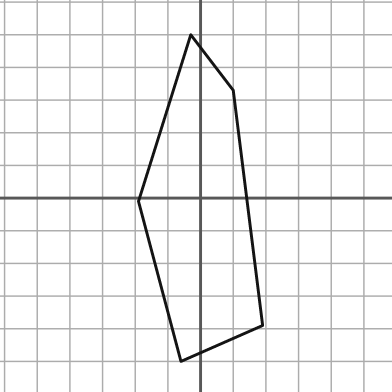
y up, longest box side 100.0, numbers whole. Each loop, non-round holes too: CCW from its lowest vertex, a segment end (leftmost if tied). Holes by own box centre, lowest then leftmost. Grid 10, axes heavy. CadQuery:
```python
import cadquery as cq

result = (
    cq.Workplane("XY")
    .moveTo(-6.0, -50.0)
    .lineTo(19.0, -39.0)
    .lineTo(10.0, 33.0)
    .lineTo(-3.0, 50.0)
    .lineTo(-19.0, -1.0)
    .close()
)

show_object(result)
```